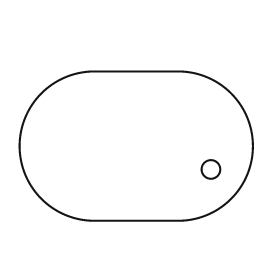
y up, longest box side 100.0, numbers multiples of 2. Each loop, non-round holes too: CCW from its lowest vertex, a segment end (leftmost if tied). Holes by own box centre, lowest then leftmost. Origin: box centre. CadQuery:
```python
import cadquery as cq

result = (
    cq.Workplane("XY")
    .moveTo(-18.0, -32.0)
    .lineTo(18.0, -32.0)
    .threePointArc((50.0, 0.0), (18.0, 32.0))
    .lineTo(-18.0, 32.0)
    .threePointArc((-50.0, 0.0), (-18.0, -32.0))
    .close()
    .moveTo(32.0, -10.0)
    .circle(4.0)
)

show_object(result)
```